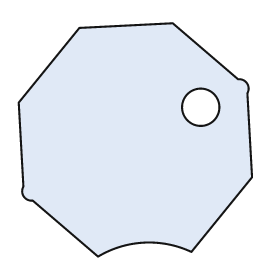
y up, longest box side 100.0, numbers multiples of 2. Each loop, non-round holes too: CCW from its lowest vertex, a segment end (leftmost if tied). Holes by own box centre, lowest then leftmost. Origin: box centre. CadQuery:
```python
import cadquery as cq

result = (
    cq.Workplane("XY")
    .moveTo(-16.0, -50.0)
    .threePointArc((4.0, -44.0), (24.0, -48.0))
    .lineTo(50.0, -16.0)
    .lineTo(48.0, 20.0)
    .threePointArc((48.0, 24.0), (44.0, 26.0))
    .lineTo(16.0, 50.0)
    .lineTo(-24.0, 48.0)
    .lineTo(-50.0, 16.0)
    .lineTo(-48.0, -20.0)
    .threePointArc((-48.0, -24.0), (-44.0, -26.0))
    .close()
    .moveTo(28.0, 14.0)
    .circle(8.0)
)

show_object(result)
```